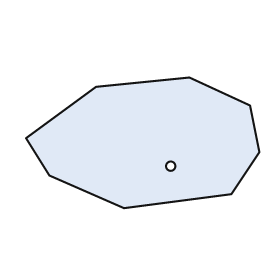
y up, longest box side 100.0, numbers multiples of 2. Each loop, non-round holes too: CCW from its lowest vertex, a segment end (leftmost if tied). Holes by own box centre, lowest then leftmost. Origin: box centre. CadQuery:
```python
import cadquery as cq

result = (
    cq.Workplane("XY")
    .moveTo(-8.0, -28.0)
    .lineTo(38.0, -22.0)
    .lineTo(50.0, -4.0)
    .lineTo(46.0, 16.0)
    .lineTo(20.0, 28.0)
    .lineTo(-20.0, 24.0)
    .lineTo(-50.0, 2.0)
    .lineTo(-40.0, -14.0)
    .close()
    .moveTo(12.0, -10.0)
    .circle(2.0)
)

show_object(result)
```